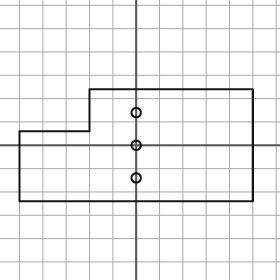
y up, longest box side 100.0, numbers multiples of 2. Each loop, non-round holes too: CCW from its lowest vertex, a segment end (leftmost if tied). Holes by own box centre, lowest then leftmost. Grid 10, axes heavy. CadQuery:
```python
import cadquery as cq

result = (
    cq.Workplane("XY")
    .moveTo(-50.0, -24.0)
    .lineTo(50.0, -24.0)
    .lineTo(50.0, 24.0)
    .lineTo(-20.0, 24.0)
    .lineTo(-20.0, 6.0)
    .lineTo(-50.0, 6.0)
    .close()
    .moveTo(0.0, -14.0)
    .circle(2.0)
    .moveTo(0.0, 0.0)
    .circle(2.0)
    .moveTo(0.0, 14.0)
    .circle(2.0)
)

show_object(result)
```